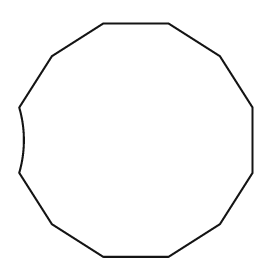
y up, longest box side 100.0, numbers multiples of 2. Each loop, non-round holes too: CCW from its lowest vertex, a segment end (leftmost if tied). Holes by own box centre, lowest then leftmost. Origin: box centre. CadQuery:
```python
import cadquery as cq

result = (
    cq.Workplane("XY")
    .moveTo(-14.0, -50.0)
    .lineTo(14.0, -50.0)
    .lineTo(36.0, -36.0)
    .lineTo(50.0, -14.0)
    .lineTo(50.0, 14.0)
    .lineTo(36.0, 36.0)
    .lineTo(14.0, 50.0)
    .lineTo(-14.0, 50.0)
    .lineTo(-36.0, 36.0)
    .lineTo(-50.0, 14.0)
    .threePointArc((-48.0, 0.0), (-50.0, -14.0))
    .lineTo(-36.0, -36.0)
    .close()
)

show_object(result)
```